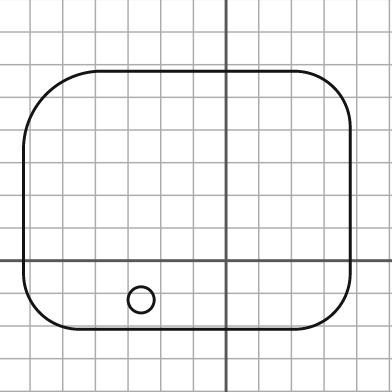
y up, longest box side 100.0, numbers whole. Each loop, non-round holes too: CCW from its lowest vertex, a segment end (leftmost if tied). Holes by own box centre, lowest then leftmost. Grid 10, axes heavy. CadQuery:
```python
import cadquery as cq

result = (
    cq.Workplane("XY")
    .moveTo(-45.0, -21.0)
    .lineTo(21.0, -21.0)
    .threePointArc((33.0, -16.0), (38.0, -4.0))
    .lineTo(38.0, 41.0)
    .threePointArc((33.0, 53.0), (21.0, 58.0))
    .lineTo(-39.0, 58.0)
    .threePointArc((-55.0, 51.0), (-62.0, 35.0))
    .lineTo(-62.0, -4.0)
    .threePointArc((-57.0, -16.0), (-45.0, -21.0))
    .close()
    .moveTo(-26.0, -12.0)
    .circle(4.0)
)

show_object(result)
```